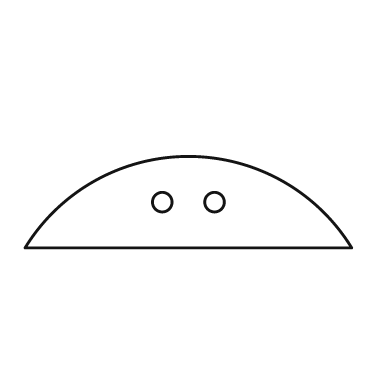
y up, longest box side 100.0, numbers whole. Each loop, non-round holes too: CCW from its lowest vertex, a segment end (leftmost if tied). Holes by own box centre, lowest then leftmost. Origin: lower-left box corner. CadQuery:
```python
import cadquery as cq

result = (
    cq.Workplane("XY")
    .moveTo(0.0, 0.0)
    .lineTo(100.0, 0.0)
    .threePointArc((50.0, 28.0), (0.0, 0.0))
    .close()
    .moveTo(42.0, 14.0)
    .circle(3.0)
    .moveTo(58.0, 14.0)
    .circle(3.0)
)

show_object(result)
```